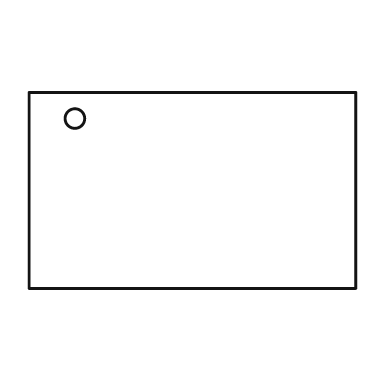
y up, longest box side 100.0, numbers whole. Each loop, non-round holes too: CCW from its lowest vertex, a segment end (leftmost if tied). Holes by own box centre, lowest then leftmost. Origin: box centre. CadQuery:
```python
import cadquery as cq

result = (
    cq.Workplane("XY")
    .moveTo(-50.0, -30.0)
    .lineTo(50.0, -30.0)
    .lineTo(50.0, 30.0)
    .lineTo(-50.0, 30.0)
    .close()
    .moveTo(-36.0, 22.0)
    .circle(3.0)
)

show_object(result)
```